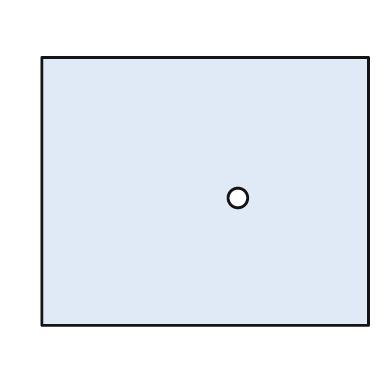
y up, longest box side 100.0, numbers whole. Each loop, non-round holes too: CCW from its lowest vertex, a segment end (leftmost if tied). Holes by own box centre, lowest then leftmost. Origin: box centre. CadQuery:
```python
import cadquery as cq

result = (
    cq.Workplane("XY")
    .moveTo(-50.0, -41.0)
    .lineTo(50.0, -41.0)
    .lineTo(50.0, 41.0)
    .lineTo(-50.0, 41.0)
    .close()
    .moveTo(10.0, -2.0)
    .circle(3.0)
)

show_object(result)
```